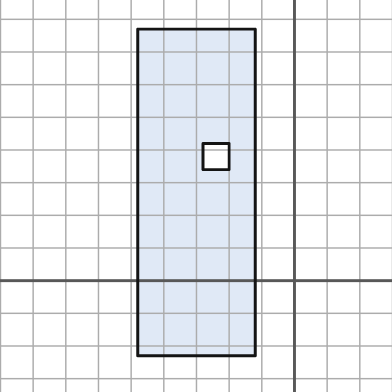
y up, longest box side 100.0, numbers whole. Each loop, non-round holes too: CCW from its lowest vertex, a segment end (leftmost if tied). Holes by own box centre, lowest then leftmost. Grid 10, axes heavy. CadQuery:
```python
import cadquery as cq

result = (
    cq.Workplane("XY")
    .moveTo(-48.0, -23.0)
    .lineTo(-12.0, -23.0)
    .lineTo(-12.0, 77.0)
    .lineTo(-48.0, 77.0)
    .close()
    .moveTo(-28.0, 34.0)
    .lineTo(-20.0, 34.0)
    .lineTo(-20.0, 42.0)
    .lineTo(-28.0, 42.0)
    .close()
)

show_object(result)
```